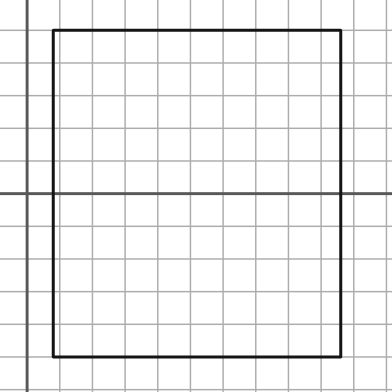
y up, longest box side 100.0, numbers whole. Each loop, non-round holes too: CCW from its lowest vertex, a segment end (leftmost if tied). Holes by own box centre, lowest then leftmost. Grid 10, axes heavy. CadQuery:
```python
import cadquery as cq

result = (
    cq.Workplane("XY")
    .moveTo(8.0, -50.0)
    .lineTo(96.0, -50.0)
    .lineTo(96.0, 50.0)
    .lineTo(8.0, 50.0)
    .close()
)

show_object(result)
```